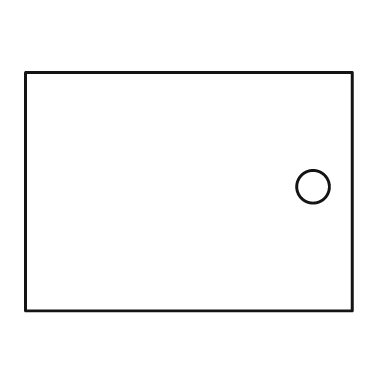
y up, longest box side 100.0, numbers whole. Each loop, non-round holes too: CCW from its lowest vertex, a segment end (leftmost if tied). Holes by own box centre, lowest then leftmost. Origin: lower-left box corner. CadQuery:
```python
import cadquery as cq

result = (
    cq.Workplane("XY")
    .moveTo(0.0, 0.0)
    .lineTo(100.0, 0.0)
    .lineTo(100.0, 73.0)
    .lineTo(0.0, 73.0)
    .close()
    .moveTo(88.0, 38.0)
    .circle(5.0)
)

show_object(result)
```